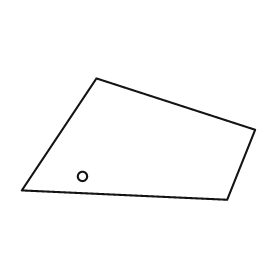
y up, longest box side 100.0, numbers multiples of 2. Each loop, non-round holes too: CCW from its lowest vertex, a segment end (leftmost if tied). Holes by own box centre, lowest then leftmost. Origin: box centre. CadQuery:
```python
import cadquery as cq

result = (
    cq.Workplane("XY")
    .moveTo(38.0, -26.0)
    .lineTo(50.0, 4.0)
    .lineTo(-18.0, 26.0)
    .lineTo(-50.0, -22.0)
    .close()
    .moveTo(-24.0, -16.0)
    .circle(2.0)
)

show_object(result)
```